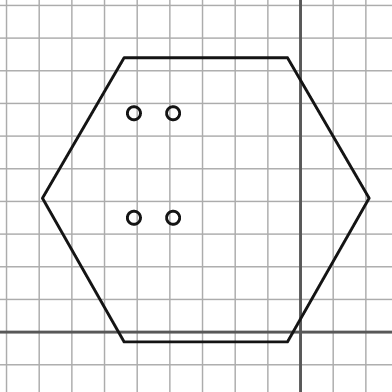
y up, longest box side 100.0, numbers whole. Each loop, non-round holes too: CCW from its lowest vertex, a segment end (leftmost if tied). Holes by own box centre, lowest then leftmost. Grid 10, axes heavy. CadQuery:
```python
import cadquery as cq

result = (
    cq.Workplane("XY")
    .moveTo(-54.0, -3.0)
    .lineTo(-4.0, -3.0)
    .lineTo(21.0, 41.0)
    .lineTo(-4.0, 84.0)
    .lineTo(-54.0, 84.0)
    .lineTo(-79.0, 41.0)
    .close()
    .moveTo(-51.0, 35.0)
    .circle(2.0)
    .moveTo(-39.0, 35.0)
    .circle(2.0)
    .moveTo(-51.0, 67.0)
    .circle(2.0)
    .moveTo(-39.0, 67.0)
    .circle(2.0)
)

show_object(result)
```